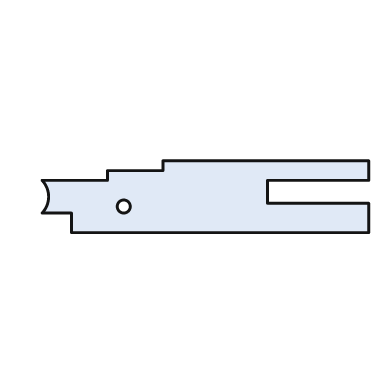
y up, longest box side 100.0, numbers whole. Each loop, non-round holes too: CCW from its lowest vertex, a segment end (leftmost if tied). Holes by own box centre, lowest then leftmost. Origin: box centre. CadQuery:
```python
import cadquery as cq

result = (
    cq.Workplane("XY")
    .moveTo(-41.0, -11.0)
    .lineTo(50.0, -11.0)
    .lineTo(50.0, -2.0)
    .lineTo(19.0, -2.0)
    .lineTo(19.0, 5.0)
    .lineTo(50.0, 5.0)
    .lineTo(50.0, 11.0)
    .lineTo(-13.0, 11.0)
    .lineTo(-13.0, 8.0)
    .lineTo(-30.0, 8.0)
    .lineTo(-30.0, 5.0)
    .lineTo(-50.0, 5.0)
    .threePointArc((-48.0, 0.0), (-50.0, -5.0))
    .lineTo(-41.0, -5.0)
    .close()
    .moveTo(-25.0, -3.0)
    .circle(2.0)
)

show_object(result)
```